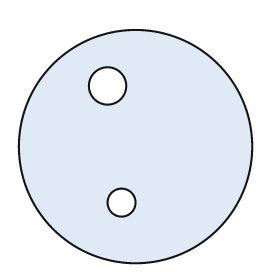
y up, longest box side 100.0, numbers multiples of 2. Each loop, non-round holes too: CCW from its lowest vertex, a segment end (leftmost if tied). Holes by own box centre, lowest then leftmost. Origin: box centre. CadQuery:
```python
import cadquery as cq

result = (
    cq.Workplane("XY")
    .moveTo(0.0, 0.0)
    .circle(50.0)
    .moveTo(-6.0, -24.0)
    .circle(6.0)
    .moveTo(-12.0, 26.0)
    .circle(8.0)
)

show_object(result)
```